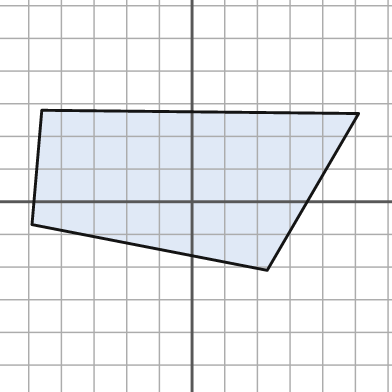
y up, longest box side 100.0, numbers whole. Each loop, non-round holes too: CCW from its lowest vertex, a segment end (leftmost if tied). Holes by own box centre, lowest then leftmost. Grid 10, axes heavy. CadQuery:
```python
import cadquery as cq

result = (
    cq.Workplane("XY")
    .moveTo(23.0, -21.0)
    .lineTo(51.0, 27.0)
    .lineTo(-46.0, 28.0)
    .lineTo(-49.0, -7.0)
    .close()
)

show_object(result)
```